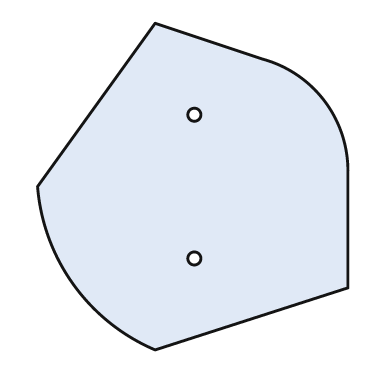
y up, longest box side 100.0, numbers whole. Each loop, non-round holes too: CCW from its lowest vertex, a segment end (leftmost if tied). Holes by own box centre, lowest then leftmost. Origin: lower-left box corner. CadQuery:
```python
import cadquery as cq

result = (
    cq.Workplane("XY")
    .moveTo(36.0, 0.0)
    .lineTo(95.0, 19.0)
    .lineTo(95.0, 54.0)
    .threePointArc((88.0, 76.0), (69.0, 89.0))
    .lineTo(36.0, 100.0)
    .lineTo(0.0, 50.0)
    .threePointArc((11.0, 20.0), (36.0, 0.0))
    .close()
    .moveTo(48.0, 28.0)
    .circle(2.0)
    .moveTo(48.0, 72.0)
    .circle(2.0)
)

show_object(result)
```